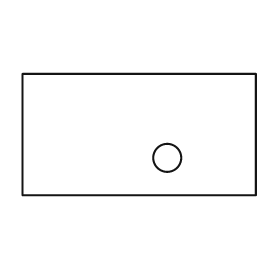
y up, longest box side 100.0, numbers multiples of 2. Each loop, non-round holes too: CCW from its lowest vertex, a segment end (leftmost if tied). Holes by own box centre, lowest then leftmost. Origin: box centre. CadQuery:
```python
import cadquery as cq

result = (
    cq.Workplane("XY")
    .moveTo(-50.0, -26.0)
    .lineTo(50.0, -26.0)
    .lineTo(50.0, 26.0)
    .lineTo(-50.0, 26.0)
    .close()
    .moveTo(12.0, -10.0)
    .circle(6.0)
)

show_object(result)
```